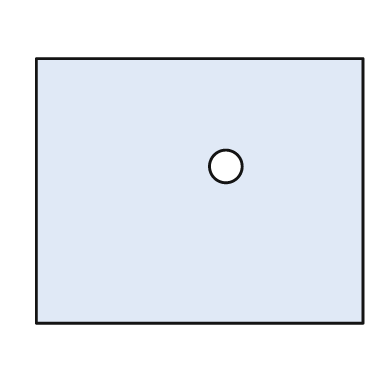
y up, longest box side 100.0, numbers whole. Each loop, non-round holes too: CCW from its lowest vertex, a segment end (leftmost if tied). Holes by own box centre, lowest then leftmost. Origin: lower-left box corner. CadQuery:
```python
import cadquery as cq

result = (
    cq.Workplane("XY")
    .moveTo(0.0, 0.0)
    .lineTo(100.0, 0.0)
    .lineTo(100.0, 81.0)
    .lineTo(0.0, 81.0)
    .close()
    .moveTo(58.0, 48.0)
    .circle(5.0)
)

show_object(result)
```